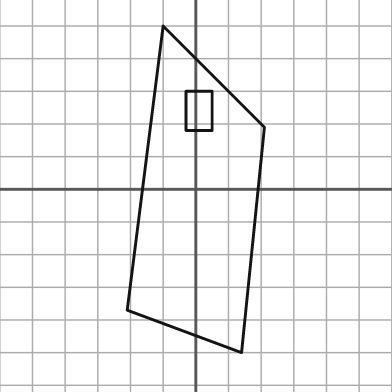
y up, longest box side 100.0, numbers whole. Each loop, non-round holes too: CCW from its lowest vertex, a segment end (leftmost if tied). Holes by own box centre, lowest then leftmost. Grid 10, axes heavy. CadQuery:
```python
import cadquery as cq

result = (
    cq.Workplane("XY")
    .moveTo(14.0, -50.0)
    .lineTo(21.0, 19.0)
    .lineTo(-10.0, 50.0)
    .lineTo(-21.0, -37.0)
    .close()
    .moveTo(-3.0, 18.0)
    .lineTo(5.0, 18.0)
    .lineTo(5.0, 30.0)
    .lineTo(-3.0, 30.0)
    .close()
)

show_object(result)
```